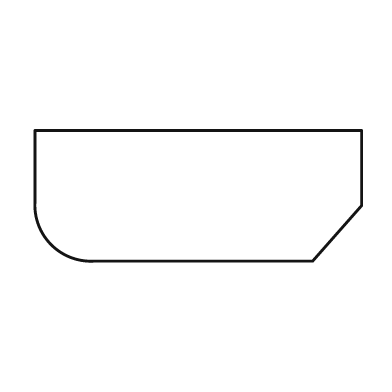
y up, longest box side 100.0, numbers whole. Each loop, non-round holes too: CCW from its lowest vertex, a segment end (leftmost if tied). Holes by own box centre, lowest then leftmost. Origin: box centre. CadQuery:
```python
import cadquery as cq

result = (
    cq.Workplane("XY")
    .moveTo(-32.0, -20.0)
    .lineTo(35.0, -20.0)
    .lineTo(50.0, -3.0)
    .lineTo(50.0, 20.0)
    .lineTo(-50.0, 20.0)
    .lineTo(-50.0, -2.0)
    .threePointArc((-45.0, -15.0), (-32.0, -20.0))
    .close()
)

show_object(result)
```